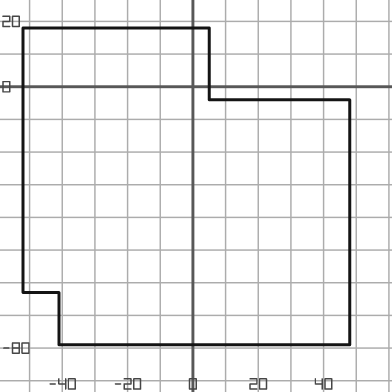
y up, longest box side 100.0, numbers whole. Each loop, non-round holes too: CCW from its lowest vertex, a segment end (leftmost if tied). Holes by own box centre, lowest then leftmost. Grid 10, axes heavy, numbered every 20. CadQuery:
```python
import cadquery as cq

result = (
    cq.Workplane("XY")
    .moveTo(-41.0, -79.0)
    .lineTo(48.0, -79.0)
    .lineTo(48.0, -4.0)
    .lineTo(5.0, -4.0)
    .lineTo(5.0, 18.0)
    .lineTo(-52.0, 18.0)
    .lineTo(-52.0, -63.0)
    .lineTo(-41.0, -63.0)
    .close()
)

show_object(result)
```